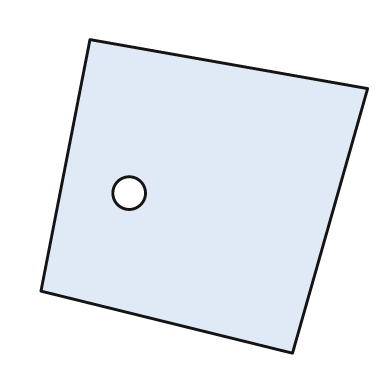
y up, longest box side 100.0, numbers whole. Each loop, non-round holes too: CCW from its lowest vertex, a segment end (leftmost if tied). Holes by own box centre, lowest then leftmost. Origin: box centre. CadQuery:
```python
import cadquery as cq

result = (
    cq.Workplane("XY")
    .moveTo(27.0, -48.0)
    .lineTo(50.0, 33.0)
    .lineTo(-35.0, 48.0)
    .lineTo(-50.0, -29.0)
    .close()
    .moveTo(-23.0, 1.0)
    .circle(5.0)
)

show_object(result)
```